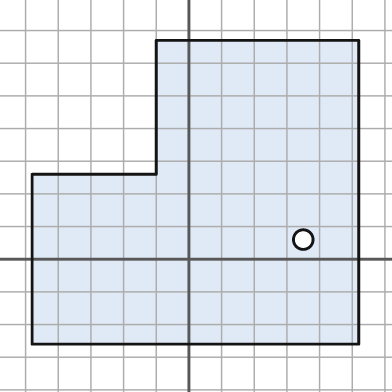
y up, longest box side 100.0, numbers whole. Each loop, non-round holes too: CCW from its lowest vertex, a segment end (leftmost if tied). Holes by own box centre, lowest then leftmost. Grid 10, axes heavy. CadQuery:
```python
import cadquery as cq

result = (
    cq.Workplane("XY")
    .moveTo(-48.0, -26.0)
    .lineTo(52.0, -26.0)
    .lineTo(52.0, 67.0)
    .lineTo(-10.0, 67.0)
    .lineTo(-10.0, 26.0)
    .lineTo(-48.0, 26.0)
    .close()
    .moveTo(35.0, 6.0)
    .circle(3.0)
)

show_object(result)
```